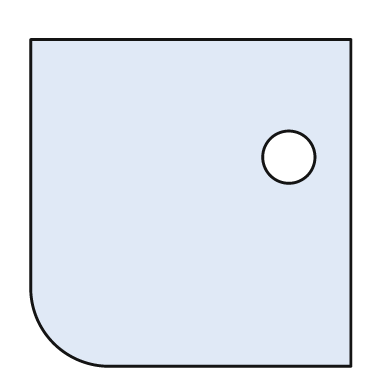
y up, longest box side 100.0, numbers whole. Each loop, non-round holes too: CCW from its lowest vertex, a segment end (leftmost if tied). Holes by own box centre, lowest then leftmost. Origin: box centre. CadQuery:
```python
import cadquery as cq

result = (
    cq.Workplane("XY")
    .moveTo(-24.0, -50.0)
    .lineTo(49.0, -50.0)
    .lineTo(49.0, 50.0)
    .lineTo(-49.0, 50.0)
    .lineTo(-49.0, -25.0)
    .threePointArc((-42.0, -43.0), (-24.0, -50.0))
    .close()
    .moveTo(30.0, 14.0)
    .circle(8.0)
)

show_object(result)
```